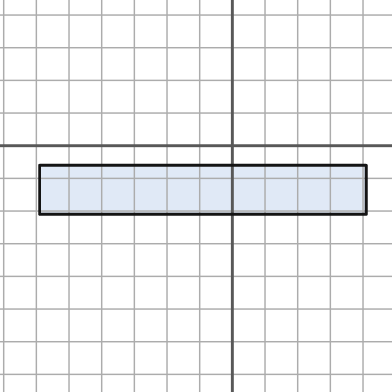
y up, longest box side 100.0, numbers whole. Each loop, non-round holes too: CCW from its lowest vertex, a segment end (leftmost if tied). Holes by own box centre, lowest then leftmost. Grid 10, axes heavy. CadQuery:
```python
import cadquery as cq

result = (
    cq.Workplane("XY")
    .moveTo(-59.0, -21.0)
    .lineTo(41.0, -21.0)
    .lineTo(41.0, -6.0)
    .lineTo(-59.0, -6.0)
    .close()
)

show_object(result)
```